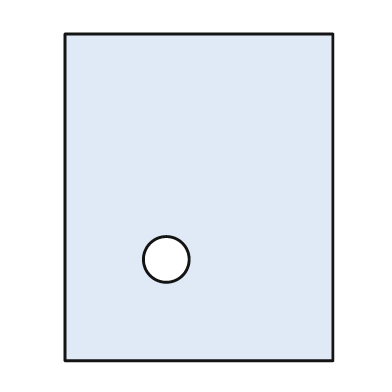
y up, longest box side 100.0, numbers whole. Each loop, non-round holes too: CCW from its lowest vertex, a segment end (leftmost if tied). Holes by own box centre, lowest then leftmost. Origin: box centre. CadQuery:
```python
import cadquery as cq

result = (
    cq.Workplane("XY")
    .moveTo(-41.0, -50.0)
    .lineTo(41.0, -50.0)
    .lineTo(41.0, 50.0)
    .lineTo(-41.0, 50.0)
    .close()
    .moveTo(-10.0, -19.0)
    .circle(7.0)
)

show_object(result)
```